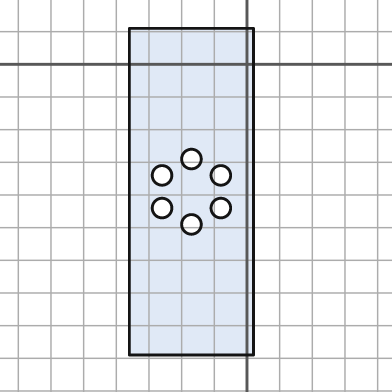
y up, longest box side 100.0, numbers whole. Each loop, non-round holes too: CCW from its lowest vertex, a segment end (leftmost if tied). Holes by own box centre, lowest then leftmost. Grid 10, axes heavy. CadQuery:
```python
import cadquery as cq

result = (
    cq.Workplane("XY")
    .moveTo(-36.0, -89.0)
    .lineTo(2.0, -89.0)
    .lineTo(2.0, 11.0)
    .lineTo(-36.0, 11.0)
    .close()
    .moveTo(-17.0, -49.0)
    .circle(3.0)
    .moveTo(-26.0, -44.0)
    .circle(3.0)
    .moveTo(-8.0, -44.0)
    .circle(3.0)
    .moveTo(-26.0, -34.0)
    .circle(3.0)
    .moveTo(-8.0, -34.0)
    .circle(3.0)
    .moveTo(-17.0, -29.0)
    .circle(3.0)
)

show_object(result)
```